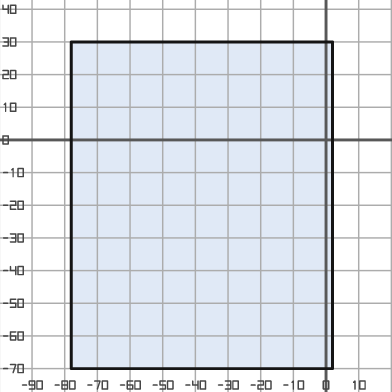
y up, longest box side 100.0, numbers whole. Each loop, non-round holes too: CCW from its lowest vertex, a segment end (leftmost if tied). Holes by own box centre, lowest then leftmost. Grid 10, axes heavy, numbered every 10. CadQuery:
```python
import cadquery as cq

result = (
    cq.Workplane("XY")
    .moveTo(-78.0, -70.0)
    .lineTo(2.0, -70.0)
    .lineTo(2.0, 30.0)
    .lineTo(-78.0, 30.0)
    .close()
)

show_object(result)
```